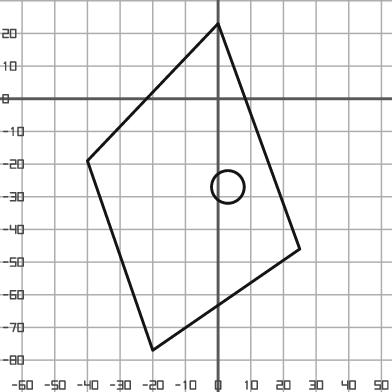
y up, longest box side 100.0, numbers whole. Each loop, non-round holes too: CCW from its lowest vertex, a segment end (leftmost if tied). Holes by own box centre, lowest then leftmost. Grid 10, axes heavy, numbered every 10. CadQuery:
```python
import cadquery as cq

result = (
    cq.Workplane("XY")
    .moveTo(-20.0, -77.0)
    .lineTo(25.0, -46.0)
    .lineTo(0.0, 23.0)
    .lineTo(-40.0, -19.0)
    .close()
    .moveTo(3.0, -27.0)
    .circle(5.0)
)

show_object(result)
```